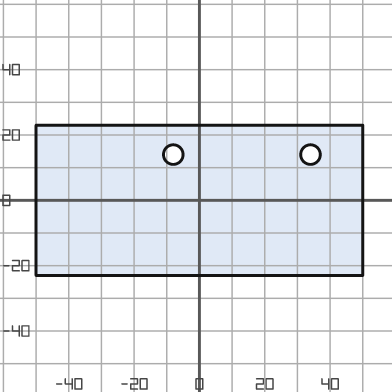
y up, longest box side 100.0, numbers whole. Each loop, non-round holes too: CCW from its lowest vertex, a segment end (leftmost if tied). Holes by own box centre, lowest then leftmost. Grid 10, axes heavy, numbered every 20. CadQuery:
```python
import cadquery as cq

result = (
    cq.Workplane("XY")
    .moveTo(-50.0, -23.0)
    .lineTo(50.0, -23.0)
    .lineTo(50.0, 23.0)
    .lineTo(-50.0, 23.0)
    .close()
    .moveTo(-8.0, 14.0)
    .circle(3.0)
    .moveTo(34.0, 14.0)
    .circle(3.0)
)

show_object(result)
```